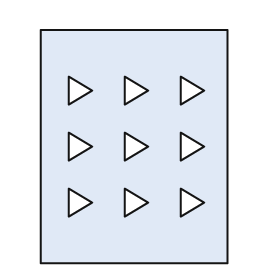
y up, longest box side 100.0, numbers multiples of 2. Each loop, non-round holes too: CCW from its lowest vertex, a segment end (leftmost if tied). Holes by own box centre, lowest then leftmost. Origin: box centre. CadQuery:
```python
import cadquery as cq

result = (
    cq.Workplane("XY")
    .moveTo(-40.0, -50.0)
    .lineTo(40.0, -50.0)
    .lineTo(40.0, 50.0)
    .lineTo(-40.0, 50.0)
    .close()
    .moveTo(-28.0, -30.0)
    .lineTo(-18.0, -24.0)
    .lineTo(-28.0, -18.0)
    .close()
    .moveTo(-4.0, -30.0)
    .lineTo(6.0, -24.0)
    .lineTo(-4.0, -18.0)
    .close()
    .moveTo(20.0, -30.0)
    .lineTo(30.0, -24.0)
    .lineTo(20.0, -18.0)
    .close()
    .moveTo(-28.0, -6.0)
    .lineTo(-18.0, 0.0)
    .lineTo(-28.0, 6.0)
    .close()
    .moveTo(-4.0, -6.0)
    .lineTo(6.0, 0.0)
    .lineTo(-4.0, 6.0)
    .close()
    .moveTo(20.0, -6.0)
    .lineTo(30.0, 0.0)
    .lineTo(20.0, 6.0)
    .close()
    .moveTo(-28.0, 18.0)
    .lineTo(-18.0, 24.0)
    .lineTo(-28.0, 30.0)
    .close()
    .moveTo(-4.0, 18.0)
    .lineTo(6.0, 24.0)
    .lineTo(-4.0, 30.0)
    .close()
    .moveTo(20.0, 18.0)
    .lineTo(30.0, 24.0)
    .lineTo(20.0, 30.0)
    .close()
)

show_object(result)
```